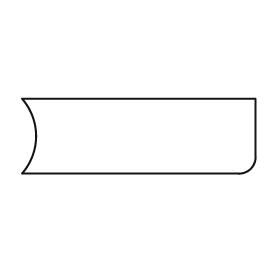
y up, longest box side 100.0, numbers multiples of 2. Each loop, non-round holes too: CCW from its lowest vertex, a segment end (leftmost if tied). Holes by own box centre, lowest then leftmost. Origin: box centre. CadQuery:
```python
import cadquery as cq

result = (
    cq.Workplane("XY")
    .moveTo(-50.0, -16.0)
    .lineTo(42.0, -16.0)
    .threePointArc((48.0, -14.0), (50.0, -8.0))
    .lineTo(50.0, 16.0)
    .lineTo(-50.0, 16.0)
    .threePointArc((-44.0, 0.0), (-50.0, -16.0))
    .close()
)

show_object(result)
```